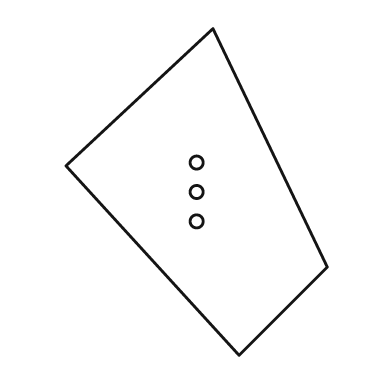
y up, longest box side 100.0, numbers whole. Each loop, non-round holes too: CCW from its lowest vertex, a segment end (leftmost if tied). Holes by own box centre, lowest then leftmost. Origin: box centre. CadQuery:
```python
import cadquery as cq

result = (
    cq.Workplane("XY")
    .moveTo(13.0, -50.0)
    .lineTo(40.0, -23.0)
    .lineTo(5.0, 50.0)
    .lineTo(-40.0, 8.0)
    .close()
    .moveTo(0.0, -9.0)
    .circle(2.0)
    .moveTo(0.0, 0.0)
    .circle(2.0)
    .moveTo(0.0, 9.0)
    .circle(2.0)
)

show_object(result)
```